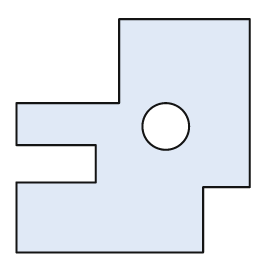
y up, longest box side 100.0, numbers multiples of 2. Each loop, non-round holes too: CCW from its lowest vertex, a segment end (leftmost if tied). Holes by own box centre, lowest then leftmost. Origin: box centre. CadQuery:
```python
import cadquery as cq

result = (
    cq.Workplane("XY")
    .moveTo(-50.0, -50.0)
    .lineTo(30.0, -50.0)
    .lineTo(30.0, -22.0)
    .lineTo(50.0, -22.0)
    .lineTo(50.0, 50.0)
    .lineTo(-6.0, 50.0)
    .lineTo(-6.0, 14.0)
    .lineTo(-50.0, 14.0)
    .lineTo(-50.0, -4.0)
    .lineTo(-16.0, -4.0)
    .lineTo(-16.0, -20.0)
    .lineTo(-50.0, -20.0)
    .close()
    .moveTo(14.0, 4.0)
    .circle(10.0)
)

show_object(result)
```